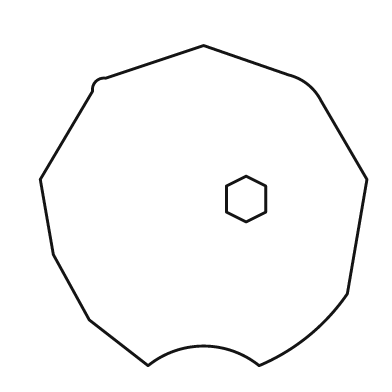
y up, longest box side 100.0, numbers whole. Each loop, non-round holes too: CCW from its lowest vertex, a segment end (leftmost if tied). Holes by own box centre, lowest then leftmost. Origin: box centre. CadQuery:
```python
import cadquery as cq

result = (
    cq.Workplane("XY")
    .moveTo(-17.0, -49.0)
    .threePointArc((0.0, -43.0), (17.0, -49.0))
    .threePointArc((32.0, -40.0), (44.0, -27.0))
    .lineTo(50.0, 8.0)
    .lineTo(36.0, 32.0)
    .threePointArc((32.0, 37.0), (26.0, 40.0))
    .lineTo(0.0, 49.0)
    .lineTo(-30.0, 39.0)
    .threePointArc((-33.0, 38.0), (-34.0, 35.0))
    .lineTo(-50.0, 8.0)
    .lineTo(-46.0, -15.0)
    .lineTo(-35.0, -35.0)
    .close()
    .moveTo(13.0, -5.0)
    .lineTo(19.0, -2.0)
    .lineTo(19.0, 6.0)
    .lineTo(13.0, 9.0)
    .lineTo(7.0, 6.0)
    .lineTo(7.0, -2.0)
    .close()
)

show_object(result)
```